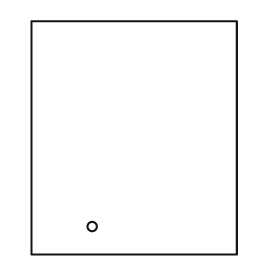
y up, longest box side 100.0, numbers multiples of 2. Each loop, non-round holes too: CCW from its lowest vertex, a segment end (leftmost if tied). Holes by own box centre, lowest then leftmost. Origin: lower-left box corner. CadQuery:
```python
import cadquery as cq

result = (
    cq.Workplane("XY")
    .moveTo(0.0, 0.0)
    .lineTo(88.0, 0.0)
    .lineTo(88.0, 100.0)
    .lineTo(0.0, 100.0)
    .close()
    .moveTo(26.0, 12.0)
    .circle(2.0)
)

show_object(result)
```